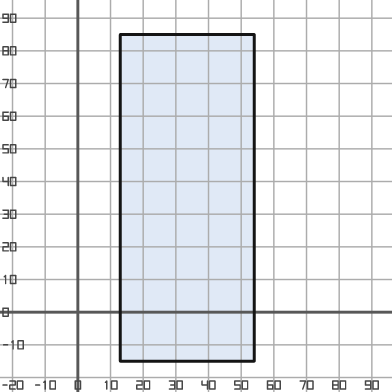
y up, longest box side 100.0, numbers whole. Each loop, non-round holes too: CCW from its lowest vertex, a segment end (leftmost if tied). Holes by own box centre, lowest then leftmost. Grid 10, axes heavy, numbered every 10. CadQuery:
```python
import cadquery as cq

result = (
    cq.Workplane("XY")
    .moveTo(13.0, -15.0)
    .lineTo(54.0, -15.0)
    .lineTo(54.0, 85.0)
    .lineTo(13.0, 85.0)
    .close()
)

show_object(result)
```